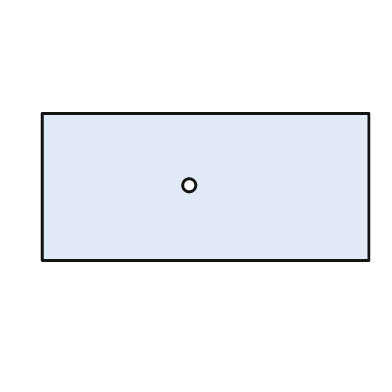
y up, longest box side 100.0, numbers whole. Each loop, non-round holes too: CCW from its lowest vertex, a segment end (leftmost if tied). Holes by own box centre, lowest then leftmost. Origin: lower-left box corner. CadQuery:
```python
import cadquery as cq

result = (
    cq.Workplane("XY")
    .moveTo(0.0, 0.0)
    .lineTo(100.0, 0.0)
    .lineTo(100.0, 45.0)
    .lineTo(0.0, 45.0)
    .close()
    .moveTo(45.0, 23.0)
    .circle(2.0)
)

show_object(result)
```